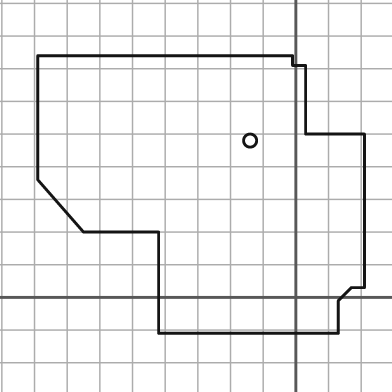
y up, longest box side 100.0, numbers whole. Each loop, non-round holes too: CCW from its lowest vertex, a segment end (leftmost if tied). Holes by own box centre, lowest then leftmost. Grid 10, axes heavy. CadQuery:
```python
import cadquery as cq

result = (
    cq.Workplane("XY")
    .moveTo(-42.0, -11.0)
    .lineTo(13.0, -11.0)
    .lineTo(13.0, -1.0)
    .lineTo(17.0, 3.0)
    .lineTo(21.0, 3.0)
    .lineTo(21.0, 50.0)
    .lineTo(3.0, 50.0)
    .lineTo(3.0, 71.0)
    .lineTo(-1.0, 71.0)
    .lineTo(-1.0, 74.0)
    .lineTo(-79.0, 74.0)
    .lineTo(-79.0, 36.0)
    .lineTo(-65.0, 20.0)
    .lineTo(-42.0, 20.0)
    .close()
    .moveTo(-14.0, 48.0)
    .circle(2.0)
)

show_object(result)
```